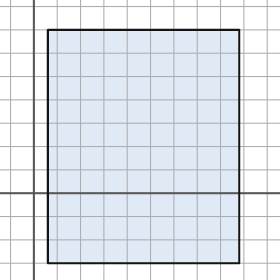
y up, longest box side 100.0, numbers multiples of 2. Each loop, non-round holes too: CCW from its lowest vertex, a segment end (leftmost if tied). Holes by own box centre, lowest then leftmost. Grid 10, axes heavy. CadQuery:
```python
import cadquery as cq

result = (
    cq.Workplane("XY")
    .moveTo(6.0, -30.0)
    .lineTo(88.0, -30.0)
    .lineTo(88.0, 70.0)
    .lineTo(6.0, 70.0)
    .close()
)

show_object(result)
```